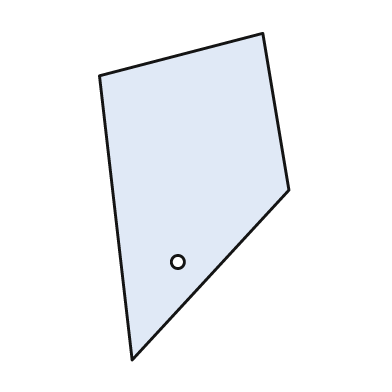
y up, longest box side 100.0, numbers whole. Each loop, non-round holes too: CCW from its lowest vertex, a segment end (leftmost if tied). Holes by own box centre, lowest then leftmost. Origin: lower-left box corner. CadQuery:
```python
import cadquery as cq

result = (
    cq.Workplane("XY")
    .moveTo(10.0, 0.0)
    .lineTo(58.0, 52.0)
    .lineTo(50.0, 100.0)
    .lineTo(0.0, 87.0)
    .close()
    .moveTo(24.0, 30.0)
    .circle(2.0)
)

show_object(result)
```